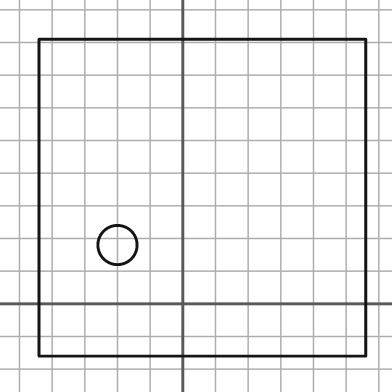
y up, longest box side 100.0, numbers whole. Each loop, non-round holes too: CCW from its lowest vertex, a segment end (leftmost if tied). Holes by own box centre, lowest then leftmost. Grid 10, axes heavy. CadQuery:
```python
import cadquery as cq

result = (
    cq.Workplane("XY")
    .moveTo(-44.0, -16.0)
    .lineTo(56.0, -16.0)
    .lineTo(56.0, 81.0)
    .lineTo(-44.0, 81.0)
    .close()
    .moveTo(-20.0, 18.0)
    .circle(6.0)
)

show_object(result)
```